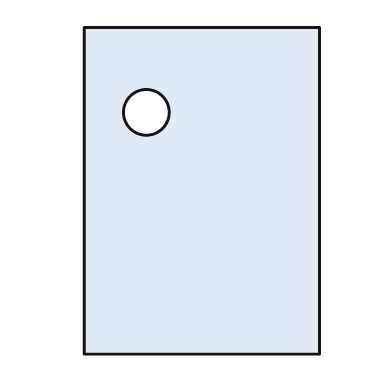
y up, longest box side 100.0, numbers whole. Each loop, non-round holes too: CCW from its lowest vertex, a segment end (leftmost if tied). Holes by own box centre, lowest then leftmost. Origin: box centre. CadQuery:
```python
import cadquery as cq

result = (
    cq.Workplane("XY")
    .moveTo(-36.0, -50.0)
    .lineTo(36.0, -50.0)
    .lineTo(36.0, 50.0)
    .lineTo(-36.0, 50.0)
    .close()
    .moveTo(-17.0, 24.0)
    .circle(7.0)
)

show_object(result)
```